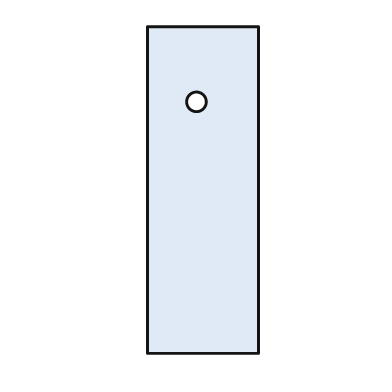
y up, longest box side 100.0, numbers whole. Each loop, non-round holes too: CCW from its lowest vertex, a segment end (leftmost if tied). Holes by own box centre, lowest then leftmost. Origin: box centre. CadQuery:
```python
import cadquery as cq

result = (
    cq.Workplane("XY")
    .moveTo(-17.0, -50.0)
    .lineTo(17.0, -50.0)
    .lineTo(17.0, 50.0)
    .lineTo(-17.0, 50.0)
    .close()
    .moveTo(-2.0, 27.0)
    .circle(3.0)
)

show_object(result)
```